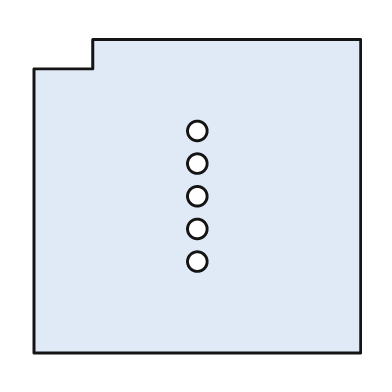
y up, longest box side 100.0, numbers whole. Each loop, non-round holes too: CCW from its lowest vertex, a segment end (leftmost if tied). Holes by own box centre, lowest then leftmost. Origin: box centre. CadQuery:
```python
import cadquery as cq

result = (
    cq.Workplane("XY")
    .moveTo(-50.0, -48.0)
    .lineTo(50.0, -48.0)
    .lineTo(50.0, 48.0)
    .lineTo(-32.0, 48.0)
    .lineTo(-32.0, 39.0)
    .lineTo(-50.0, 39.0)
    .close()
    .moveTo(0.0, -20.0)
    .circle(3.0)
    .moveTo(0.0, -10.0)
    .circle(3.0)
    .moveTo(0.0, 0.0)
    .circle(3.0)
    .moveTo(0.0, 10.0)
    .circle(3.0)
    .moveTo(0.0, 20.0)
    .circle(3.0)
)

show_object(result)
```